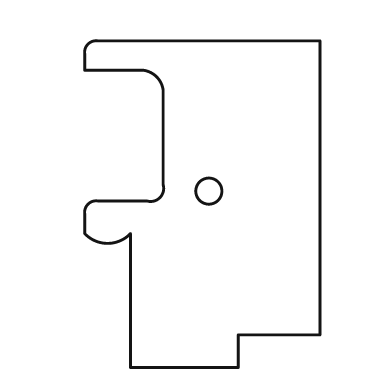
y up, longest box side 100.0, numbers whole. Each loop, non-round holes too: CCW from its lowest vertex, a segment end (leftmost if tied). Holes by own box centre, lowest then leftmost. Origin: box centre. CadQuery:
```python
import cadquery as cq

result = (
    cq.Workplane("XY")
    .moveTo(-22.0, -50.0)
    .lineTo(11.0, -50.0)
    .lineTo(11.0, -40.0)
    .lineTo(36.0, -40.0)
    .lineTo(36.0, 50.0)
    .lineTo(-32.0, 50.0)
    .threePointArc((-35.0, 49.0), (-36.0, 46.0))
    .lineTo(-36.0, 41.0)
    .lineTo(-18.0, 41.0)
    .threePointArc((-14.0, 39.0), (-12.0, 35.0))
    .lineTo(-12.0, 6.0)
    .threePointArc((-13.0, 2.0), (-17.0, 1.0))
    .lineTo(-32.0, 1.0)
    .threePointArc((-35.0, 0.0), (-36.0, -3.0))
    .lineTo(-36.0, -9.0)
    .threePointArc((-29.0, -12.0), (-22.0, -9.0))
    .close()
    .moveTo(2.0, 4.0)
    .circle(4.0)
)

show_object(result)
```